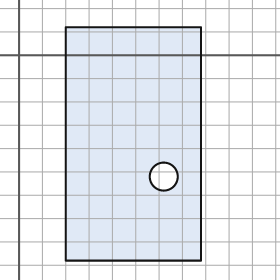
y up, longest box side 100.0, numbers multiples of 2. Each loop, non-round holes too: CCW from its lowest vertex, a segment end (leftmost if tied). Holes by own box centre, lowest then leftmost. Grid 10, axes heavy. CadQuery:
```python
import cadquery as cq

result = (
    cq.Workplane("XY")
    .moveTo(20.0, -88.0)
    .lineTo(78.0, -88.0)
    .lineTo(78.0, 12.0)
    .lineTo(20.0, 12.0)
    .close()
    .moveTo(62.0, -52.0)
    .circle(6.0)
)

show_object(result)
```